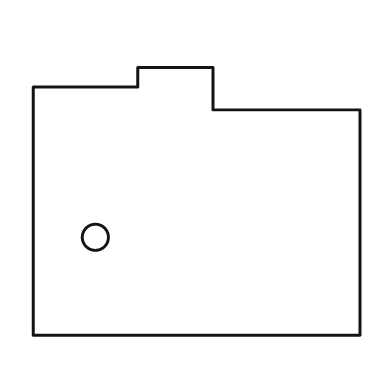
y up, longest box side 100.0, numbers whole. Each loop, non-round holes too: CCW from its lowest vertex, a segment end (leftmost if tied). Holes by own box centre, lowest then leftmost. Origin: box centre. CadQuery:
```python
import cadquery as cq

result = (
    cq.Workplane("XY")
    .moveTo(-50.0, -41.0)
    .lineTo(50.0, -41.0)
    .lineTo(50.0, 28.0)
    .lineTo(5.0, 28.0)
    .lineTo(5.0, 41.0)
    .lineTo(-18.0, 41.0)
    .lineTo(-18.0, 35.0)
    .lineTo(-50.0, 35.0)
    .close()
    .moveTo(-31.0, -11.0)
    .circle(4.0)
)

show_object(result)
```